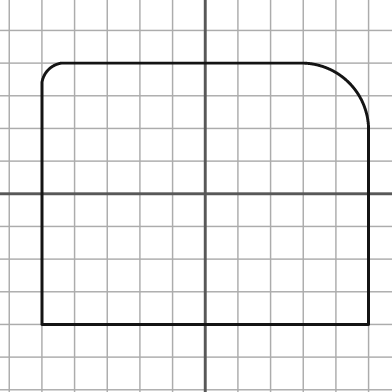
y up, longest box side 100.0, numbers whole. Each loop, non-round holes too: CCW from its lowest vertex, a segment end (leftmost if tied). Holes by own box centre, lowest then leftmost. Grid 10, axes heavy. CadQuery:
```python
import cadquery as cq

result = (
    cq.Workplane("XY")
    .moveTo(-50.0, -40.0)
    .lineTo(50.0, -40.0)
    .lineTo(50.0, 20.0)
    .threePointArc((44.0, 34.0), (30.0, 40.0))
    .lineTo(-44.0, 40.0)
    .threePointArc((-48.0, 38.0), (-50.0, 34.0))
    .close()
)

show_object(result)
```